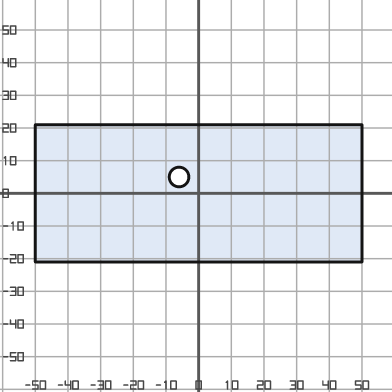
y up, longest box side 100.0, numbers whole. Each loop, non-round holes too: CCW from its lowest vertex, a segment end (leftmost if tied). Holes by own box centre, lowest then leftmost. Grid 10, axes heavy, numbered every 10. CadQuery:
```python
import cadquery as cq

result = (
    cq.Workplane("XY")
    .moveTo(-50.0, -21.0)
    .lineTo(50.0, -21.0)
    .lineTo(50.0, 21.0)
    .lineTo(-50.0, 21.0)
    .close()
    .moveTo(-6.0, 5.0)
    .circle(3.0)
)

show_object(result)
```